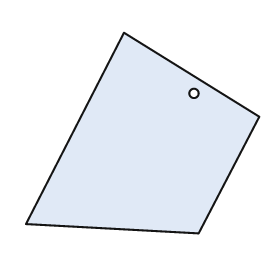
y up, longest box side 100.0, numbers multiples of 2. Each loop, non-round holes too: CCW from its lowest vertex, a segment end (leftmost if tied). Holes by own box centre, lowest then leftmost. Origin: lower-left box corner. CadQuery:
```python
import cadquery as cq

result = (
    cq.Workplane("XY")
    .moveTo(74.0, 0.0)
    .lineTo(100.0, 50.0)
    .lineTo(42.0, 86.0)
    .lineTo(0.0, 4.0)
    .close()
    .moveTo(72.0, 60.0)
    .circle(2.0)
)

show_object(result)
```